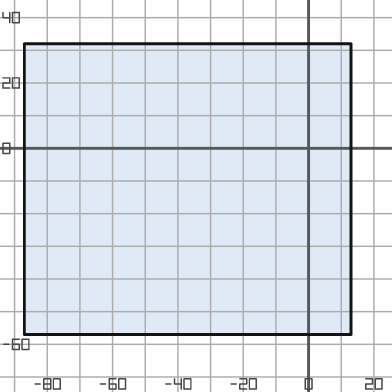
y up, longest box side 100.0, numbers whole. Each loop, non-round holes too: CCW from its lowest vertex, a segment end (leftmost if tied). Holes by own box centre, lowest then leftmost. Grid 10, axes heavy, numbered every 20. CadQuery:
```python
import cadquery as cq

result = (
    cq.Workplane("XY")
    .moveTo(-87.0, -57.0)
    .lineTo(13.0, -57.0)
    .lineTo(13.0, 32.0)
    .lineTo(-87.0, 32.0)
    .close()
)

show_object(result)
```